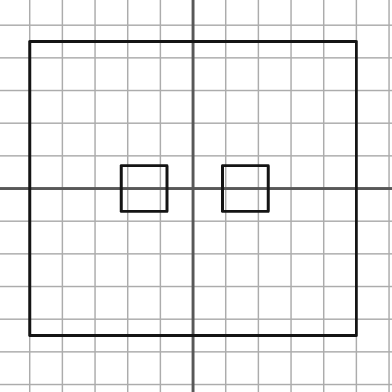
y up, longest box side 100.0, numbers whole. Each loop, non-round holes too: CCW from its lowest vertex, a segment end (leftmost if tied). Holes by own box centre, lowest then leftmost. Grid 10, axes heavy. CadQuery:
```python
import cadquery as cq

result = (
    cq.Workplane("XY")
    .moveTo(-50.0, -45.0)
    .lineTo(50.0, -45.0)
    .lineTo(50.0, 45.0)
    .lineTo(-50.0, 45.0)
    .close()
    .moveTo(-22.0, -7.0)
    .lineTo(-8.0, -7.0)
    .lineTo(-8.0, 7.0)
    .lineTo(-22.0, 7.0)
    .close()
    .moveTo(9.0, -7.0)
    .lineTo(23.0, -7.0)
    .lineTo(23.0, 7.0)
    .lineTo(9.0, 7.0)
    .close()
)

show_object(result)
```